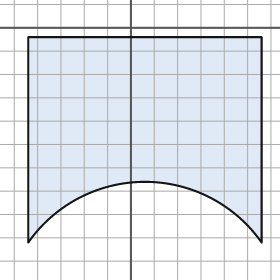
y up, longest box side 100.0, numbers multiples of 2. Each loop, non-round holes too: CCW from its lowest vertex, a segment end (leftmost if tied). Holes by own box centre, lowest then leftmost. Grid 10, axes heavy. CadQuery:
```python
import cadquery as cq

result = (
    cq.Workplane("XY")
    .moveTo(-44.0, -92.0)
    .threePointArc((6.0, -66.0), (56.0, -92.0))
    .lineTo(56.0, -4.0)
    .lineTo(-44.0, -4.0)
    .close()
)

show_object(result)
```